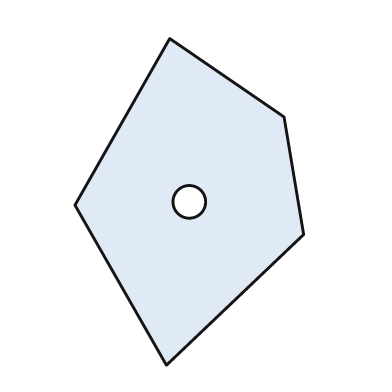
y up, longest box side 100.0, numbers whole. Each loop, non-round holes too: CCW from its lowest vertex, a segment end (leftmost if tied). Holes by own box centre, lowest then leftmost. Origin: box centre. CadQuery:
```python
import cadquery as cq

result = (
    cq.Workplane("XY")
    .moveTo(-7.0, -50.0)
    .lineTo(35.0, -10.0)
    .lineTo(29.0, 26.0)
    .lineTo(-6.0, 50.0)
    .lineTo(-35.0, -1.0)
    .close()
    .moveTo(0.0, 0.0)
    .circle(5.0)
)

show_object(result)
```